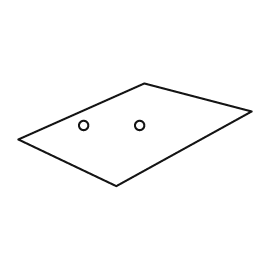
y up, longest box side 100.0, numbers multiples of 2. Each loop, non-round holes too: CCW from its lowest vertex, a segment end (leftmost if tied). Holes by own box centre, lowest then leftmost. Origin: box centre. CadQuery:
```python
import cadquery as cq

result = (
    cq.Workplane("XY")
    .moveTo(-8.0, -22.0)
    .lineTo(50.0, 10.0)
    .lineTo(4.0, 22.0)
    .lineTo(-50.0, -2.0)
    .close()
    .moveTo(-22.0, 4.0)
    .circle(2.0)
    .moveTo(2.0, 4.0)
    .circle(2.0)
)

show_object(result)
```